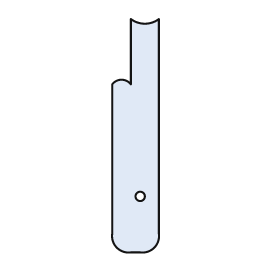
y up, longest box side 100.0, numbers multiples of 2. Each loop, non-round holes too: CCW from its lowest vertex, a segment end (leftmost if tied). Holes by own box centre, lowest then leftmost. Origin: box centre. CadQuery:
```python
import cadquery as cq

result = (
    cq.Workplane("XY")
    .moveTo(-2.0, -50.0)
    .lineTo(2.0, -50.0)
    .threePointArc((8.0, -48.0), (10.0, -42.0))
    .lineTo(10.0, 50.0)
    .threePointArc((4.0, 48.0), (-2.0, 50.0))
    .lineTo(-2.0, 22.0)
    .threePointArc((-6.0, 24.0), (-10.0, 22.0))
    .lineTo(-10.0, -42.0)
    .threePointArc((-8.0, -48.0), (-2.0, -50.0))
    .close()
    .moveTo(2.0, -26.0)
    .circle(2.0)
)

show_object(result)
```